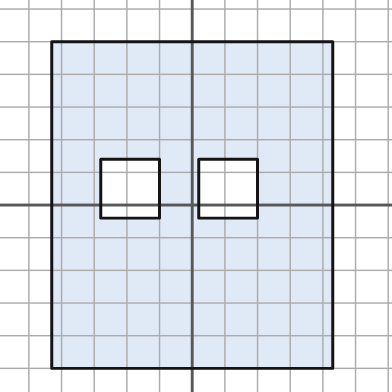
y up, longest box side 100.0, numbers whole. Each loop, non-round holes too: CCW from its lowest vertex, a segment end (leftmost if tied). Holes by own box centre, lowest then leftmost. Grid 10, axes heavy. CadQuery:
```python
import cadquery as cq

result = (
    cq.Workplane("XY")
    .moveTo(-43.0, -50.0)
    .lineTo(43.0, -50.0)
    .lineTo(43.0, 50.0)
    .lineTo(-43.0, 50.0)
    .close()
    .moveTo(-28.0, -4.0)
    .lineTo(-10.0, -4.0)
    .lineTo(-10.0, 14.0)
    .lineTo(-28.0, 14.0)
    .close()
    .moveTo(2.0, -4.0)
    .lineTo(20.0, -4.0)
    .lineTo(20.0, 14.0)
    .lineTo(2.0, 14.0)
    .close()
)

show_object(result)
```